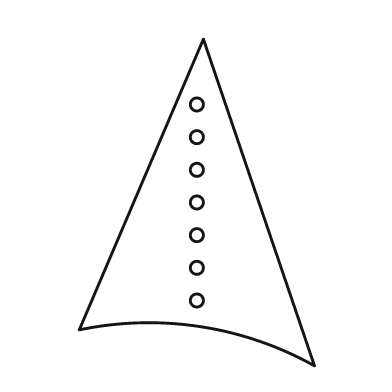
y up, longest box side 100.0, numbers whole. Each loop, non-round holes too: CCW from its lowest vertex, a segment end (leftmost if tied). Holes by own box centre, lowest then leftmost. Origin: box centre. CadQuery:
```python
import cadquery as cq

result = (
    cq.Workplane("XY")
    .moveTo(36.0, -50.0)
    .lineTo(2.0, 50.0)
    .lineTo(-36.0, -39.0)
    .threePointArc((1.0, -38.0), (36.0, -50.0))
    .close()
    .moveTo(0.0, -30.0)
    .circle(2.0)
    .moveTo(0.0, -20.0)
    .circle(2.0)
    .moveTo(0.0, -10.0)
    .circle(2.0)
    .moveTo(0.0, 0.0)
    .circle(2.0)
    .moveTo(0.0, 10.0)
    .circle(2.0)
    .moveTo(0.0, 20.0)
    .circle(2.0)
    .moveTo(0.0, 30.0)
    .circle(2.0)
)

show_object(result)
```